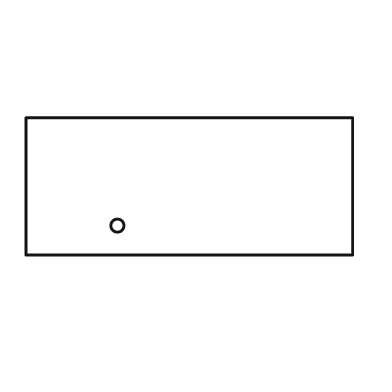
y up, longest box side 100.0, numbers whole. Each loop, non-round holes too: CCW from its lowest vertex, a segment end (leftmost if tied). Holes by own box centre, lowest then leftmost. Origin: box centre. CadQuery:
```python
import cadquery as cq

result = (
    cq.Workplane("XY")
    .moveTo(-50.0, -21.0)
    .lineTo(50.0, -21.0)
    .lineTo(50.0, 21.0)
    .lineTo(-50.0, 21.0)
    .close()
    .moveTo(-22.0, -12.0)
    .circle(2.0)
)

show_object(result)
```